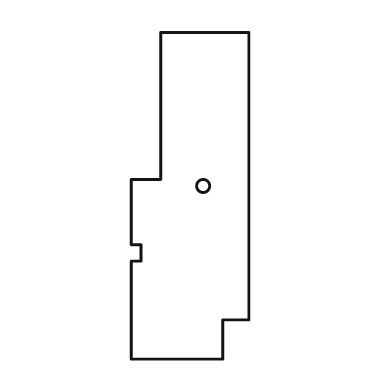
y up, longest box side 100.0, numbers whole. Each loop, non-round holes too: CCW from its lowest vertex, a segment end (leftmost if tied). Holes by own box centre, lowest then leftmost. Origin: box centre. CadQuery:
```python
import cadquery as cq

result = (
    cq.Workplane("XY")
    .moveTo(-18.0, -50.0)
    .lineTo(10.0, -50.0)
    .lineTo(10.0, -38.0)
    .lineTo(18.0, -38.0)
    .lineTo(18.0, 50.0)
    .lineTo(-9.0, 50.0)
    .lineTo(-9.0, 5.0)
    .lineTo(-18.0, 5.0)
    .lineTo(-18.0, -15.0)
    .lineTo(-15.0, -15.0)
    .lineTo(-15.0, -20.0)
    .lineTo(-18.0, -20.0)
    .close()
    .moveTo(4.0, 3.0)
    .circle(2.0)
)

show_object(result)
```